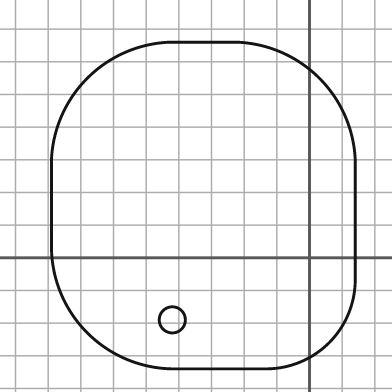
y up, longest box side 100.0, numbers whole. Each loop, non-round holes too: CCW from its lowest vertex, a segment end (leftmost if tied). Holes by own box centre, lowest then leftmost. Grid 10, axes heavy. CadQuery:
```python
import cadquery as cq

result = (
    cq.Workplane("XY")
    .moveTo(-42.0, -34.0)
    .lineTo(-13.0, -34.0)
    .threePointArc((6.0, -26.0), (14.0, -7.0))
    .lineTo(14.0, 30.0)
    .threePointArc((3.0, 55.0), (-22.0, 66.0))
    .lineTo(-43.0, 66.0)
    .threePointArc((-68.0, 55.0), (-79.0, 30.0))
    .lineTo(-79.0, 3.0)
    .threePointArc((-68.0, -23.0), (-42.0, -34.0))
    .close()
    .moveTo(-42.0, -19.0)
    .circle(4.0)
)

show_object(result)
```